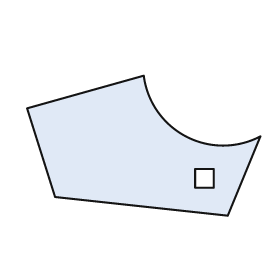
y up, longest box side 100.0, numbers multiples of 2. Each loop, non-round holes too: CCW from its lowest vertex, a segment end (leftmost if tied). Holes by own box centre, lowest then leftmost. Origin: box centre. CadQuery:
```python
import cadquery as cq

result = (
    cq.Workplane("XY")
    .moveTo(36.0, -30.0)
    .lineTo(50.0, 4.0)
    .threePointArc((18.0, 4.0), (0.0, 30.0))
    .lineTo(-50.0, 16.0)
    .lineTo(-38.0, -22.0)
    .close()
    .moveTo(22.0, -18.0)
    .lineTo(30.0, -18.0)
    .lineTo(30.0, -10.0)
    .lineTo(22.0, -10.0)
    .close()
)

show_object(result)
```